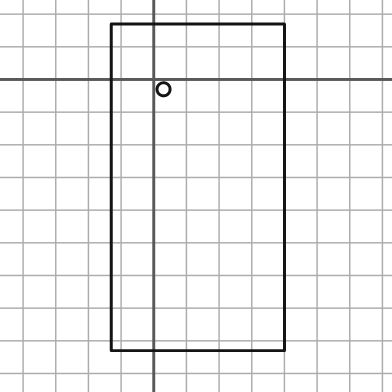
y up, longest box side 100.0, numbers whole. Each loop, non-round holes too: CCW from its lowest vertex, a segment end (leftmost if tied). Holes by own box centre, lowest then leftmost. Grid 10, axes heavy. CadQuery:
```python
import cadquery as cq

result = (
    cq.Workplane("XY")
    .moveTo(-13.0, -83.0)
    .lineTo(40.0, -83.0)
    .lineTo(40.0, 17.0)
    .lineTo(-13.0, 17.0)
    .close()
    .moveTo(3.0, -3.0)
    .circle(2.0)
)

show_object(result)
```